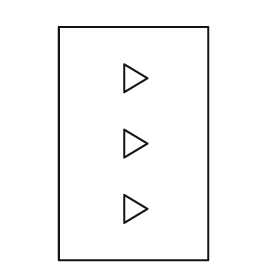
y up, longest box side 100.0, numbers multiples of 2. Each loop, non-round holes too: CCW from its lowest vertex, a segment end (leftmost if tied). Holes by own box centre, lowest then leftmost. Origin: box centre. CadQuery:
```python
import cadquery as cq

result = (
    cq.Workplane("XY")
    .moveTo(-32.0, -50.0)
    .lineTo(32.0, -50.0)
    .lineTo(32.0, 50.0)
    .lineTo(-32.0, 50.0)
    .close()
    .moveTo(-4.0, -34.0)
    .lineTo(6.0, -28.0)
    .lineTo(-4.0, -22.0)
    .close()
    .moveTo(-4.0, -6.0)
    .lineTo(6.0, 0.0)
    .lineTo(-4.0, 6.0)
    .close()
    .moveTo(-4.0, 22.0)
    .lineTo(6.0, 28.0)
    .lineTo(-4.0, 34.0)
    .close()
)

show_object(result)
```